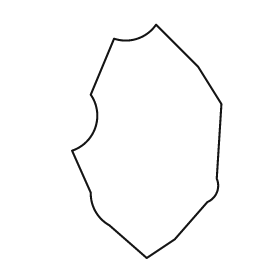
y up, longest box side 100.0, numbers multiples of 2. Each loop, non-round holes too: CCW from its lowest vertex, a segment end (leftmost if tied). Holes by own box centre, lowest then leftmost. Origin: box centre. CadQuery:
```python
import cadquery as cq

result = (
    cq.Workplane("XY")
    .moveTo(0.0, -50.0)
    .lineTo(12.0, -42.0)
    .lineTo(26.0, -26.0)
    .threePointArc((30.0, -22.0), (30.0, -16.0))
    .lineTo(32.0, 16.0)
    .lineTo(22.0, 32.0)
    .lineTo(4.0, 50.0)
    .threePointArc((-4.0, 44.0), (-14.0, 44.0))
    .lineTo(-24.0, 20.0)
    .threePointArc((-22.0, 6.0), (-32.0, -4.0))
    .lineTo(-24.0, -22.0)
    .threePointArc((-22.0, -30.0), (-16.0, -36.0))
    .close()
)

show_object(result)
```